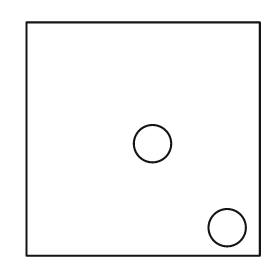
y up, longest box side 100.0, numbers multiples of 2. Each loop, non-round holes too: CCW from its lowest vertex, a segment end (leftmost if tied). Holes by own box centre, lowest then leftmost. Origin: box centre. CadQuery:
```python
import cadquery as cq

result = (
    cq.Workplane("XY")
    .moveTo(-50.0, -50.0)
    .lineTo(50.0, -50.0)
    .lineTo(50.0, 50.0)
    .lineTo(-50.0, 50.0)
    .close()
    .moveTo(36.0, -38.0)
    .circle(8.0)
    .moveTo(4.0, -2.0)
    .circle(8.0)
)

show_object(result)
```